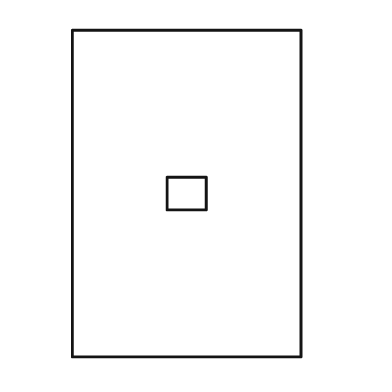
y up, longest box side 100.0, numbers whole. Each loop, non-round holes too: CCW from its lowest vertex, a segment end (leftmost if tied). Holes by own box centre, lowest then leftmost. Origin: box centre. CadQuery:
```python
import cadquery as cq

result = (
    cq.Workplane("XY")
    .moveTo(-35.0, -50.0)
    .lineTo(35.0, -50.0)
    .lineTo(35.0, 50.0)
    .lineTo(-35.0, 50.0)
    .close()
    .moveTo(-6.0, -5.0)
    .lineTo(6.0, -5.0)
    .lineTo(6.0, 5.0)
    .lineTo(-6.0, 5.0)
    .close()
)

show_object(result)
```